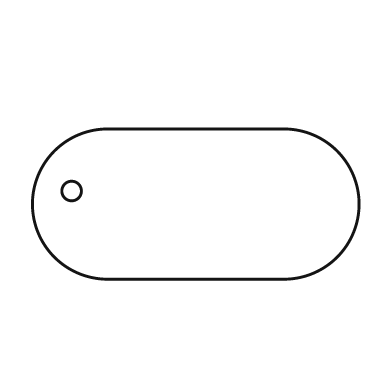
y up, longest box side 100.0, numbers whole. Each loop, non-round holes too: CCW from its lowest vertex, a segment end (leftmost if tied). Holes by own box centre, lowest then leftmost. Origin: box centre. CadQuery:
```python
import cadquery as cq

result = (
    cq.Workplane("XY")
    .moveTo(-27.0, -23.0)
    .lineTo(27.0, -23.0)
    .threePointArc((50.0, 0.0), (27.0, 23.0))
    .lineTo(-27.0, 23.0)
    .threePointArc((-50.0, 0.0), (-27.0, -23.0))
    .close()
    .moveTo(-38.0, 4.0)
    .circle(3.0)
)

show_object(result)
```